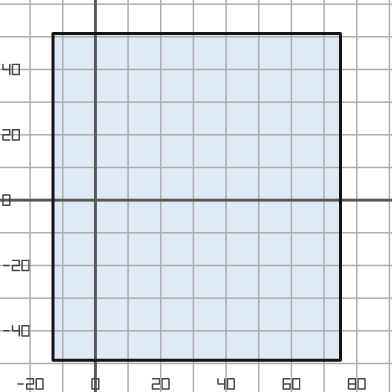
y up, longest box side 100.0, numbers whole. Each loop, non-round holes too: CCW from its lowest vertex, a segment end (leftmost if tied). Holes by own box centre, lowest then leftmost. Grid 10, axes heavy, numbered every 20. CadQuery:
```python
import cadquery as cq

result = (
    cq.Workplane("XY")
    .moveTo(-13.0, -49.0)
    .lineTo(75.0, -49.0)
    .lineTo(75.0, 51.0)
    .lineTo(-13.0, 51.0)
    .close()
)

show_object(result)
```